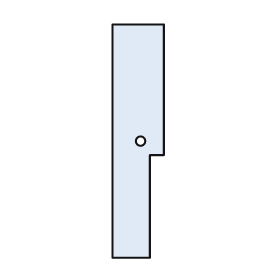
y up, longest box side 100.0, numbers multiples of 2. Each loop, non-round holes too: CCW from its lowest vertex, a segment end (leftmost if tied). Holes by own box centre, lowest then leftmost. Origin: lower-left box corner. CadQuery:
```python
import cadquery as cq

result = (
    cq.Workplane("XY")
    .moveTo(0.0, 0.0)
    .lineTo(16.0, 0.0)
    .lineTo(16.0, 44.0)
    .lineTo(22.0, 44.0)
    .lineTo(22.0, 100.0)
    .lineTo(0.0, 100.0)
    .close()
    .moveTo(12.0, 50.0)
    .circle(2.0)
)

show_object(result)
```